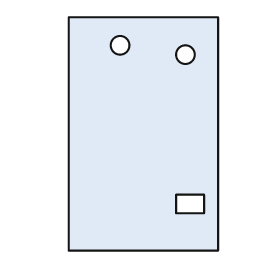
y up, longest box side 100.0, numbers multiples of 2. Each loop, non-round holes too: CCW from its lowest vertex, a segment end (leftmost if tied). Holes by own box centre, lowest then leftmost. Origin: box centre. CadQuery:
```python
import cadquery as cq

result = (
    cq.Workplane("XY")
    .moveTo(-32.0, -50.0)
    .lineTo(32.0, -50.0)
    .lineTo(32.0, 50.0)
    .lineTo(-32.0, 50.0)
    .close()
    .moveTo(14.0, -34.0)
    .lineTo(26.0, -34.0)
    .lineTo(26.0, -26.0)
    .lineTo(14.0, -26.0)
    .close()
    .moveTo(18.0, 34.0)
    .circle(4.0)
    .moveTo(-10.0, 38.0)
    .circle(4.0)
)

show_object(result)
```